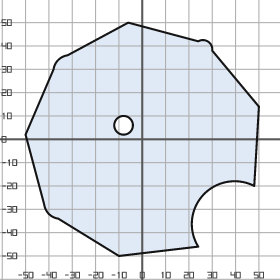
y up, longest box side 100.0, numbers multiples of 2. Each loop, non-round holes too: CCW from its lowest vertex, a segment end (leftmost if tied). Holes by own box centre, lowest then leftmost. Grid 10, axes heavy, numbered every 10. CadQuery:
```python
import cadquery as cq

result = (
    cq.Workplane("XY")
    .moveTo(-10.0, -50.0)
    .lineTo(24.0, -46.0)
    .threePointArc((26.0, -24.0), (48.0, -20.0))
    .lineTo(50.0, 14.0)
    .lineTo(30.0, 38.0)
    .threePointArc((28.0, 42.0), (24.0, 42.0))
    .lineTo(-6.0, 50.0)
    .lineTo(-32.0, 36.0)
    .threePointArc((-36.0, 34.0), (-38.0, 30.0))
    .lineTo(-50.0, 2.0)
    .lineTo(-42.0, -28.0)
    .threePointArc((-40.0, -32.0), (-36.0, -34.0))
    .close()
    .moveTo(-8.0, 6.0)
    .circle(4.0)
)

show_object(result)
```